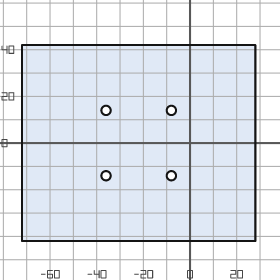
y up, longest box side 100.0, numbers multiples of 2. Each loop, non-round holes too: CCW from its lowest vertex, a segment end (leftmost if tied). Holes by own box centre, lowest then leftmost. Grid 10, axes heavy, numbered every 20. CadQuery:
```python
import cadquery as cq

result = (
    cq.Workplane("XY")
    .moveTo(-72.0, -42.0)
    .lineTo(28.0, -42.0)
    .lineTo(28.0, 42.0)
    .lineTo(-72.0, 42.0)
    .close()
    .moveTo(-36.0, -14.0)
    .circle(2.0)
    .moveTo(-8.0, -14.0)
    .circle(2.0)
    .moveTo(-36.0, 14.0)
    .circle(2.0)
    .moveTo(-8.0, 14.0)
    .circle(2.0)
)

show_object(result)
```